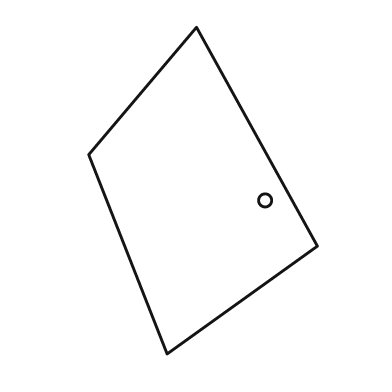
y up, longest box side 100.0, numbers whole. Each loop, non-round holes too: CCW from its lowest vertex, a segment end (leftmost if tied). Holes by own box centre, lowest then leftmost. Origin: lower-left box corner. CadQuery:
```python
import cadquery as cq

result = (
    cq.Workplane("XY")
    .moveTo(24.0, 0.0)
    .lineTo(70.0, 33.0)
    .lineTo(33.0, 100.0)
    .lineTo(0.0, 61.0)
    .close()
    .moveTo(54.0, 47.0)
    .circle(2.0)
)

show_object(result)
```